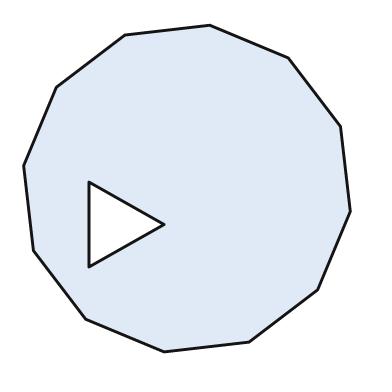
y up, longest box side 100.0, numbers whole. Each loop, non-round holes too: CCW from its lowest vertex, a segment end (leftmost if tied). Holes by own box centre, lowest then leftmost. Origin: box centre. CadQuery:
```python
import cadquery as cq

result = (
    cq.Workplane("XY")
    .moveTo(-7.0, -50.0)
    .lineTo(19.0, -47.0)
    .lineTo(40.0, -31.0)
    .lineTo(50.0, -7.0)
    .lineTo(47.0, 19.0)
    .lineTo(31.0, 40.0)
    .lineTo(7.0, 50.0)
    .lineTo(-19.0, 47.0)
    .lineTo(-40.0, 31.0)
    .lineTo(-50.0, 7.0)
    .lineTo(-47.0, -19.0)
    .lineTo(-31.0, -40.0)
    .close()
    .moveTo(-30.0, -24.0)
    .lineTo(-7.0, -11.0)
    .lineTo(-30.0, 2.0)
    .close()
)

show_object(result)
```